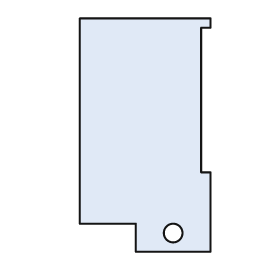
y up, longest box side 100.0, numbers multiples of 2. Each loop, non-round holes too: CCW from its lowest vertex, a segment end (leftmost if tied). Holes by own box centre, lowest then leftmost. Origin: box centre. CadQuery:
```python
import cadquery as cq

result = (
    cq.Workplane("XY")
    .moveTo(-4.0, -50.0)
    .lineTo(28.0, -50.0)
    .lineTo(28.0, -16.0)
    .lineTo(24.0, -16.0)
    .lineTo(24.0, 46.0)
    .lineTo(28.0, 46.0)
    .lineTo(28.0, 50.0)
    .lineTo(-28.0, 50.0)
    .lineTo(-28.0, -38.0)
    .lineTo(-4.0, -38.0)
    .close()
    .moveTo(12.0, -42.0)
    .circle(4.0)
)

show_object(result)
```